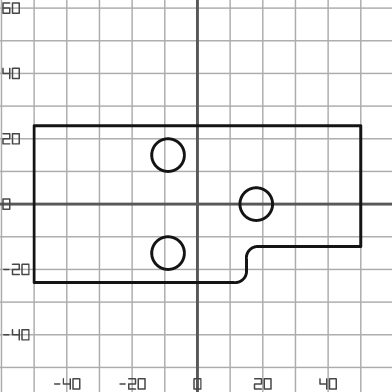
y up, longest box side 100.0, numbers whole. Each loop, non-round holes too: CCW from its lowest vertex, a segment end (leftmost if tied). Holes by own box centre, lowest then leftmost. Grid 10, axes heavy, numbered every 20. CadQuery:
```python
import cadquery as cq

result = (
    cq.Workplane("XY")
    .moveTo(-50.0, -24.0)
    .lineTo(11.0, -24.0)
    .threePointArc((14.0, -23.0), (15.0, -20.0))
    .lineTo(15.0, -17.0)
    .threePointArc((16.0, -14.0), (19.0, -13.0))
    .lineTo(50.0, -13.0)
    .lineTo(50.0, 24.0)
    .lineTo(-50.0, 24.0)
    .close()
    .moveTo(-9.0, -15.0)
    .circle(5.0)
    .moveTo(18.0, 0.0)
    .circle(5.0)
    .moveTo(-9.0, 15.0)
    .circle(5.0)
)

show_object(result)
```